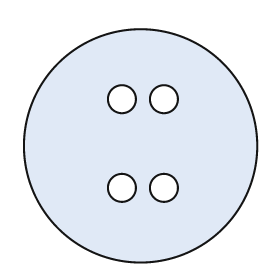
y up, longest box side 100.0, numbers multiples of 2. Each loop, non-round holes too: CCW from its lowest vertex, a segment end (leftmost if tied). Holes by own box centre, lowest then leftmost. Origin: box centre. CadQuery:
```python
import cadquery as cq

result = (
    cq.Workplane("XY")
    .moveTo(0.0, 0.0)
    .circle(50.0)
    .moveTo(-8.0, -18.0)
    .circle(6.0)
    .moveTo(10.0, -18.0)
    .circle(6.0)
    .moveTo(-8.0, 20.0)
    .circle(6.0)
    .moveTo(10.0, 20.0)
    .circle(6.0)
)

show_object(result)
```